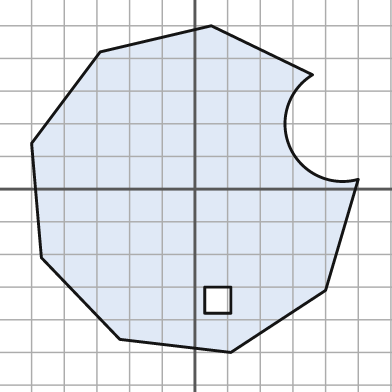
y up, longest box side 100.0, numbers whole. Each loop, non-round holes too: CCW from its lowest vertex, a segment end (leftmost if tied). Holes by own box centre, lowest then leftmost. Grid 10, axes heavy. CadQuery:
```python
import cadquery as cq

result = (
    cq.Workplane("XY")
    .moveTo(11.0, -50.0)
    .lineTo(40.0, -31.0)
    .lineTo(50.0, 3.0)
    .threePointArc((29.0, 13.0), (36.0, 35.0))
    .lineTo(5.0, 50.0)
    .lineTo(-29.0, 42.0)
    .lineTo(-50.0, 14.0)
    .lineTo(-47.0, -21.0)
    .lineTo(-23.0, -46.0)
    .close()
    .moveTo(3.0, -38.0)
    .lineTo(11.0, -38.0)
    .lineTo(11.0, -30.0)
    .lineTo(3.0, -30.0)
    .close()
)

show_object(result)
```